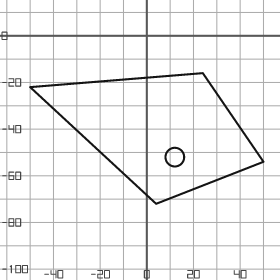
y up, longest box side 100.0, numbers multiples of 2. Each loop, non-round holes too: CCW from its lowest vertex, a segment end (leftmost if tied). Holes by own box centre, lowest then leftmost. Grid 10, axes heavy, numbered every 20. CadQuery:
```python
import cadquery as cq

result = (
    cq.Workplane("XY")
    .moveTo(4.0, -72.0)
    .lineTo(50.0, -54.0)
    .lineTo(24.0, -16.0)
    .lineTo(-50.0, -22.0)
    .close()
    .moveTo(12.0, -52.0)
    .circle(4.0)
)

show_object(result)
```